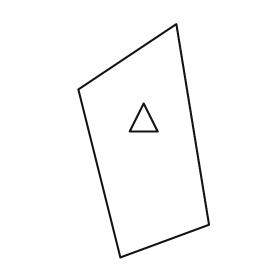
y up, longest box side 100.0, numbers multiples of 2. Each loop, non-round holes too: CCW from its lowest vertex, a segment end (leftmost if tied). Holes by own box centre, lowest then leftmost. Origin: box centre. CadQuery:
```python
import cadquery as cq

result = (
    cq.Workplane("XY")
    .moveTo(-10.0, -50.0)
    .lineTo(28.0, -36.0)
    .lineTo(14.0, 50.0)
    .lineTo(-28.0, 22.0)
    .close()
    .moveTo(-6.0, 4.0)
    .lineTo(6.0, 4.0)
    .lineTo(0.0, 16.0)
    .close()
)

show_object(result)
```